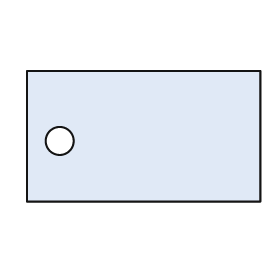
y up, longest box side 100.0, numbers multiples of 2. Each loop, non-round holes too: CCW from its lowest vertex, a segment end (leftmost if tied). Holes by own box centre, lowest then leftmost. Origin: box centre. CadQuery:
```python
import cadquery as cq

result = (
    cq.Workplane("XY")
    .moveTo(-50.0, -28.0)
    .lineTo(50.0, -28.0)
    .lineTo(50.0, 28.0)
    .lineTo(-50.0, 28.0)
    .close()
    .moveTo(-36.0, -2.0)
    .circle(6.0)
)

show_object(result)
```